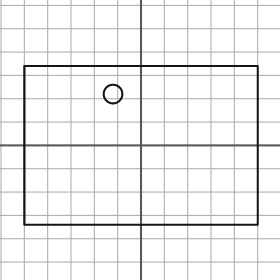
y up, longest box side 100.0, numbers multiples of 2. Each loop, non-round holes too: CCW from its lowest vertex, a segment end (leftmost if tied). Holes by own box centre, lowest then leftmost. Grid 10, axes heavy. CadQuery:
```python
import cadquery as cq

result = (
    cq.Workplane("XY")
    .moveTo(-50.0, -34.0)
    .lineTo(50.0, -34.0)
    .lineTo(50.0, 34.0)
    .lineTo(-50.0, 34.0)
    .close()
    .moveTo(-12.0, 22.0)
    .circle(4.0)
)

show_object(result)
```